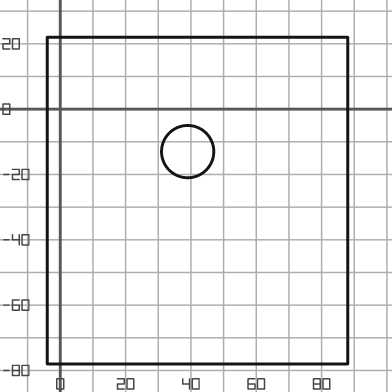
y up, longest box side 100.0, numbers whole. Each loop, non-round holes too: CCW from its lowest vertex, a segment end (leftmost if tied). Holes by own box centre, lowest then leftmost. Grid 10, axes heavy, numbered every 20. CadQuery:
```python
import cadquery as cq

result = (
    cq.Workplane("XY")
    .moveTo(-4.0, -78.0)
    .lineTo(88.0, -78.0)
    .lineTo(88.0, 22.0)
    .lineTo(-4.0, 22.0)
    .close()
    .moveTo(39.0, -13.0)
    .circle(8.0)
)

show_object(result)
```